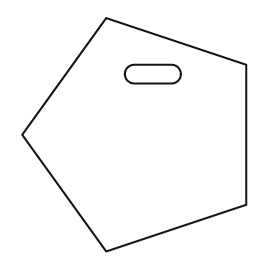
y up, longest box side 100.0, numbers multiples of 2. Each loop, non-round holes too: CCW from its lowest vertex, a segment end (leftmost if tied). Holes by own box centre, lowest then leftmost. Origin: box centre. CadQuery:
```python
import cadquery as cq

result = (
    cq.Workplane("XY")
    .moveTo(-12.0, -50.0)
    .lineTo(48.0, -30.0)
    .lineTo(48.0, 30.0)
    .lineTo(-12.0, 50.0)
    .lineTo(-48.0, 0.0)
    .close()
    .moveTo(0.0, 22.0)
    .lineTo(16.0, 22.0)
    .threePointArc((20.0, 26.0), (16.0, 30.0))
    .lineTo(0.0, 30.0)
    .threePointArc((-4.0, 26.0), (0.0, 22.0))
    .close()
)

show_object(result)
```